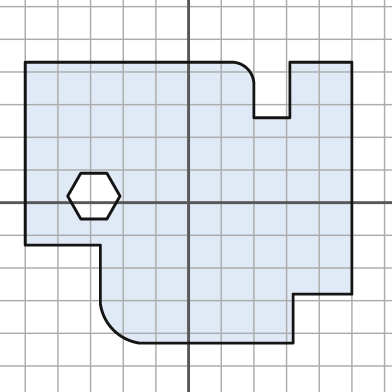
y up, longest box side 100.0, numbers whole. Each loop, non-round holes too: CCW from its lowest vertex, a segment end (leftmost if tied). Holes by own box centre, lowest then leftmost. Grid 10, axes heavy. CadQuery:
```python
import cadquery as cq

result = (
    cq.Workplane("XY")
    .moveTo(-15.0, -43.0)
    .lineTo(32.0, -43.0)
    .lineTo(32.0, -28.0)
    .lineTo(50.0, -28.0)
    .lineTo(50.0, 43.0)
    .lineTo(31.0, 43.0)
    .lineTo(31.0, 26.0)
    .lineTo(20.0, 26.0)
    .lineTo(20.0, 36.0)
    .threePointArc((18.0, 41.0), (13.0, 43.0))
    .lineTo(-50.0, 43.0)
    .lineTo(-50.0, -13.0)
    .lineTo(-27.0, -13.0)
    .lineTo(-27.0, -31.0)
    .threePointArc((-23.0, -39.0), (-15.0, -43.0))
    .close()
    .moveTo(-33.0, -5.0)
    .lineTo(-25.0, -5.0)
    .lineTo(-21.0, 2.0)
    .lineTo(-25.0, 9.0)
    .lineTo(-33.0, 9.0)
    .lineTo(-37.0, 2.0)
    .close()
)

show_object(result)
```